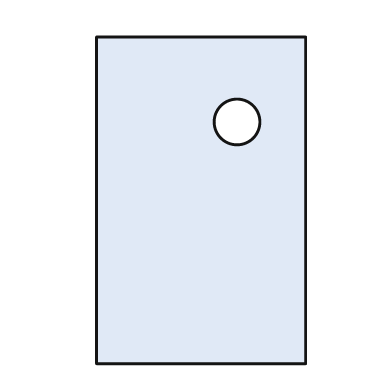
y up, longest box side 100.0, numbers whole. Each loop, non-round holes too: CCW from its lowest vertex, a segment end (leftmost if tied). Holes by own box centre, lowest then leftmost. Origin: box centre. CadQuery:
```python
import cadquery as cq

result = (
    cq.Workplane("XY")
    .moveTo(-32.0, -50.0)
    .lineTo(32.0, -50.0)
    .lineTo(32.0, 50.0)
    .lineTo(-32.0, 50.0)
    .close()
    .moveTo(11.0, 24.0)
    .circle(7.0)
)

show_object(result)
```